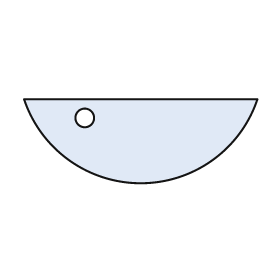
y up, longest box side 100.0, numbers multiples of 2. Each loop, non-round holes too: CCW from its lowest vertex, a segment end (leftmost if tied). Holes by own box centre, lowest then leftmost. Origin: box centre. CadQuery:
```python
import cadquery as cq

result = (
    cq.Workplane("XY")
    .moveTo(-50.0, 18.0)
    .threePointArc((0.0, -18.0), (50.0, 18.0))
    .close()
    .moveTo(-24.0, 10.0)
    .circle(4.0)
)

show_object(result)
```